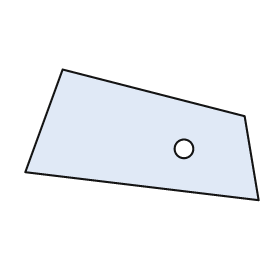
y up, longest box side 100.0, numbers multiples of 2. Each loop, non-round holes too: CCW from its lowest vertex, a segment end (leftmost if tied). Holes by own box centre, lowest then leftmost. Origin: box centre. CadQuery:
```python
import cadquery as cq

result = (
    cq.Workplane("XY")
    .moveTo(50.0, -28.0)
    .lineTo(44.0, 8.0)
    .lineTo(-34.0, 28.0)
    .lineTo(-50.0, -16.0)
    .close()
    .moveTo(18.0, -6.0)
    .circle(4.0)
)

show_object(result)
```